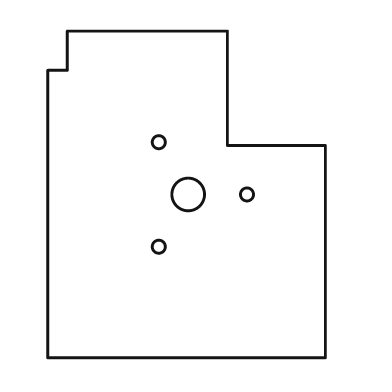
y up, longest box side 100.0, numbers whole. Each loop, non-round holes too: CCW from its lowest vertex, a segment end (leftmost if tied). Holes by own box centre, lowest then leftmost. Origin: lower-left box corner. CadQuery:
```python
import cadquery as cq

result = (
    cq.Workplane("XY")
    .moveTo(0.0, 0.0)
    .lineTo(85.0, 0.0)
    .lineTo(85.0, 65.0)
    .lineTo(55.0, 65.0)
    .lineTo(55.0, 100.0)
    .lineTo(6.0, 100.0)
    .lineTo(6.0, 88.0)
    .lineTo(0.0, 88.0)
    .close()
    .moveTo(34.0, 34.0)
    .circle(2.0)
    .moveTo(43.0, 50.0)
    .circle(5.0)
    .moveTo(61.0, 50.0)
    .circle(2.0)
    .moveTo(34.0, 66.0)
    .circle(2.0)
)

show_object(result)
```